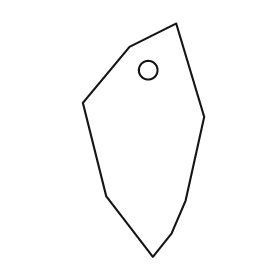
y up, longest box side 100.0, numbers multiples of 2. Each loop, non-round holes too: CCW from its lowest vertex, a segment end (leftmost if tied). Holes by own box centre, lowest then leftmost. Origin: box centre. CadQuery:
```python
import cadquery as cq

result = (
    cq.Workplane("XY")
    .moveTo(4.0, -50.0)
    .lineTo(12.0, -40.0)
    .lineTo(18.0, -26.0)
    .lineTo(26.0, 10.0)
    .lineTo(14.0, 50.0)
    .lineTo(-6.0, 40.0)
    .lineTo(-26.0, 16.0)
    .lineTo(-16.0, -24.0)
    .close()
    .moveTo(2.0, 30.0)
    .circle(4.0)
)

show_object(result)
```